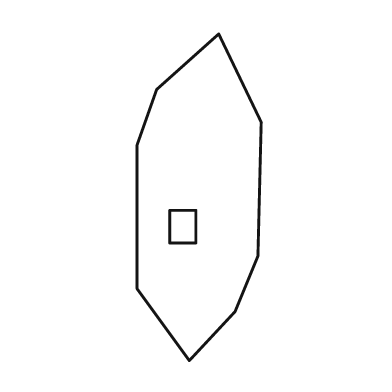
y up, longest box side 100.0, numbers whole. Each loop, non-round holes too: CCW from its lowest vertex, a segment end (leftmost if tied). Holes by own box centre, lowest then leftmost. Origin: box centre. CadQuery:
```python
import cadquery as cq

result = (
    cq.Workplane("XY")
    .moveTo(-3.0, -50.0)
    .lineTo(11.0, -35.0)
    .lineTo(18.0, -18.0)
    .lineTo(19.0, 23.0)
    .lineTo(6.0, 50.0)
    .lineTo(-13.0, 33.0)
    .lineTo(-19.0, 16.0)
    .lineTo(-19.0, -28.0)
    .close()
    .moveTo(-9.0, -14.0)
    .lineTo(-1.0, -14.0)
    .lineTo(-1.0, -4.0)
    .lineTo(-9.0, -4.0)
    .close()
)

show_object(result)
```